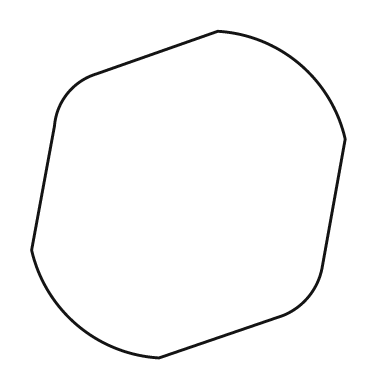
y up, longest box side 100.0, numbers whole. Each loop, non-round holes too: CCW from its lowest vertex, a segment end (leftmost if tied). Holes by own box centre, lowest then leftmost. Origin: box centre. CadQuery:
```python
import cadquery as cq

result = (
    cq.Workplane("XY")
    .moveTo(-9.0, -50.0)
    .lineTo(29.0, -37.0)
    .threePointArc((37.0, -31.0), (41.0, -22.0))
    .lineTo(48.0, 17.0)
    .threePointArc((34.0, 40.0), (9.0, 50.0))
    .lineTo(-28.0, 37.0)
    .threePointArc((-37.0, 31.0), (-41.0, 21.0))
    .lineTo(-48.0, -17.0)
    .threePointArc((-34.0, -40.0), (-9.0, -50.0))
    .close()
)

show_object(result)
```